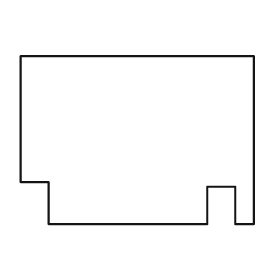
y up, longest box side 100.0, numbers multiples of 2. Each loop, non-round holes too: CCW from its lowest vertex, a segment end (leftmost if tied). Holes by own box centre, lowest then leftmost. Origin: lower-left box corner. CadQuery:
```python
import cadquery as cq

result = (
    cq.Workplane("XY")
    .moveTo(12.0, 0.0)
    .lineTo(80.0, 0.0)
    .lineTo(80.0, 16.0)
    .lineTo(92.0, 16.0)
    .lineTo(92.0, 0.0)
    .lineTo(100.0, 0.0)
    .lineTo(100.0, 72.0)
    .lineTo(0.0, 72.0)
    .lineTo(0.0, 18.0)
    .lineTo(12.0, 18.0)
    .close()
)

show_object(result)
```